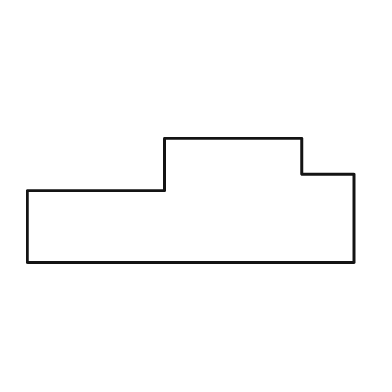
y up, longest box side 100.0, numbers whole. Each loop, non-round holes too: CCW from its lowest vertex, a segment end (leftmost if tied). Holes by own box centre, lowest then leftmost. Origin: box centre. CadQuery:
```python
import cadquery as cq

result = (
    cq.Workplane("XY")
    .moveTo(-50.0, -19.0)
    .lineTo(50.0, -19.0)
    .lineTo(50.0, 8.0)
    .lineTo(34.0, 8.0)
    .lineTo(34.0, 19.0)
    .lineTo(-8.0, 19.0)
    .lineTo(-8.0, 3.0)
    .lineTo(-50.0, 3.0)
    .close()
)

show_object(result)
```